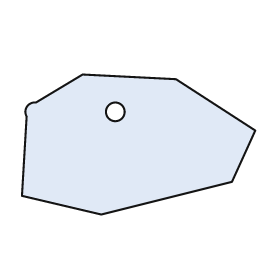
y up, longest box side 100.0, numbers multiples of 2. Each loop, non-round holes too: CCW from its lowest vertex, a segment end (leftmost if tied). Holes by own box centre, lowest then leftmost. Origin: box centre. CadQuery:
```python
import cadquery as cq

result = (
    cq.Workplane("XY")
    .moveTo(-16.0, -30.0)
    .lineTo(40.0, -16.0)
    .lineTo(50.0, 6.0)
    .lineTo(16.0, 28.0)
    .lineTo(-24.0, 30.0)
    .lineTo(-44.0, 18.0)
    .threePointArc((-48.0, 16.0), (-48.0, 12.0))
    .lineTo(-50.0, -22.0)
    .close()
    .moveTo(-10.0, 14.0)
    .circle(4.0)
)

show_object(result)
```